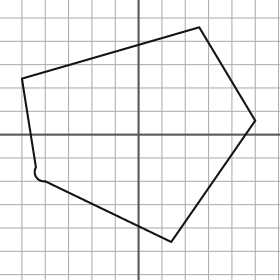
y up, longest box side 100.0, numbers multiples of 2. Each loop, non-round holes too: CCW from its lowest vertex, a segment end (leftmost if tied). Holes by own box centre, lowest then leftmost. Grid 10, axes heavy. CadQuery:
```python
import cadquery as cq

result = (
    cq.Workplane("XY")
    .moveTo(14.0, -46.0)
    .lineTo(50.0, 6.0)
    .lineTo(26.0, 46.0)
    .lineTo(-50.0, 24.0)
    .lineTo(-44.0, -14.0)
    .threePointArc((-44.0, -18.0), (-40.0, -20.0))
    .close()
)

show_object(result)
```